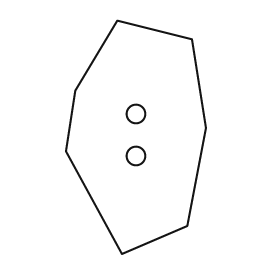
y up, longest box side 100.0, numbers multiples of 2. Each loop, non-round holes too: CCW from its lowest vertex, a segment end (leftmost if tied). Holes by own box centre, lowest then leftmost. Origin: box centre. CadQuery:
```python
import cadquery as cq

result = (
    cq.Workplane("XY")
    .moveTo(-6.0, -50.0)
    .lineTo(22.0, -38.0)
    .lineTo(30.0, 4.0)
    .lineTo(24.0, 42.0)
    .lineTo(-8.0, 50.0)
    .lineTo(-26.0, 20.0)
    .lineTo(-30.0, -6.0)
    .close()
    .moveTo(0.0, -8.0)
    .circle(4.0)
    .moveTo(0.0, 10.0)
    .circle(4.0)
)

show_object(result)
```